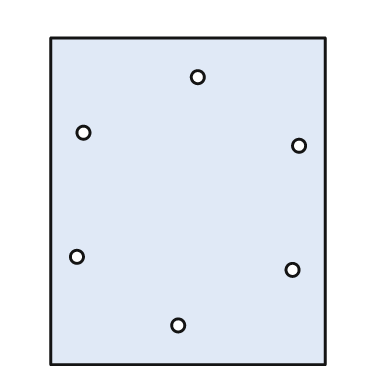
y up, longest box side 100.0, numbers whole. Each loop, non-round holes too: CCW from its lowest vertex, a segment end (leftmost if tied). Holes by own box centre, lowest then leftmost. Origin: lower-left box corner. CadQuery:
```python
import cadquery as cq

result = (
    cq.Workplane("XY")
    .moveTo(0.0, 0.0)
    .lineTo(84.0, 0.0)
    .lineTo(84.0, 100.0)
    .lineTo(0.0, 100.0)
    .close()
    .moveTo(39.0, 12.0)
    .circle(2.0)
    .moveTo(74.0, 29.0)
    .circle(2.0)
    .moveTo(8.0, 33.0)
    .circle(2.0)
    .moveTo(76.0, 67.0)
    .circle(2.0)
    .moveTo(10.0, 71.0)
    .circle(2.0)
    .moveTo(45.0, 88.0)
    .circle(2.0)
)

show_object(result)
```